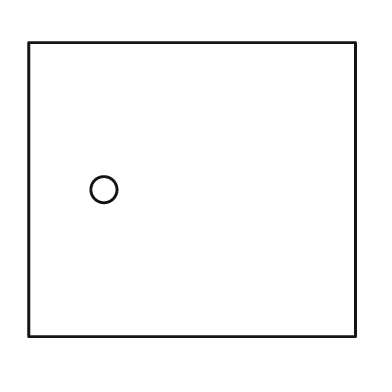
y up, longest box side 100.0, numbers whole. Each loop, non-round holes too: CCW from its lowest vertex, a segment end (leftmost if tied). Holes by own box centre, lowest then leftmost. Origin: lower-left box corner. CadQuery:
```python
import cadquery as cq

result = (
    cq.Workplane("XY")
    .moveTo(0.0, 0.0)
    .lineTo(100.0, 0.0)
    .lineTo(100.0, 90.0)
    .lineTo(0.0, 90.0)
    .close()
    .moveTo(23.0, 45.0)
    .circle(4.0)
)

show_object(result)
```